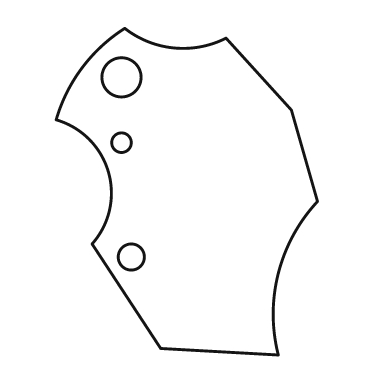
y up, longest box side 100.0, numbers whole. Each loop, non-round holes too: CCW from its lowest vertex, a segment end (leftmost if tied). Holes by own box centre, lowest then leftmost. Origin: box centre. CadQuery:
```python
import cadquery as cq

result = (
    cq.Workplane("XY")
    .moveTo(28.0, -50.0)
    .threePointArc((28.0, -25.0), (40.0, -3.0))
    .lineTo(32.0, 25.0)
    .lineTo(12.0, 47.0)
    .threePointArc((-4.0, 44.0), (-19.0, 50.0))
    .threePointArc((-32.0, 38.0), (-40.0, 22.0))
    .threePointArc((-24.0, 6.0), (-29.0, -16.0))
    .lineTo(-8.0, -48.0)
    .close()
    .moveTo(-17.0, -20.0)
    .circle(4.0)
    .moveTo(-20.0, 15.0)
    .circle(3.0)
    .moveTo(-20.0, 35.0)
    .circle(6.0)
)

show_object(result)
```